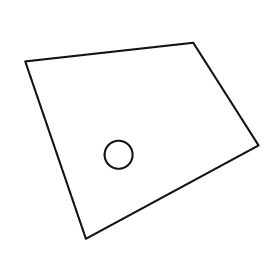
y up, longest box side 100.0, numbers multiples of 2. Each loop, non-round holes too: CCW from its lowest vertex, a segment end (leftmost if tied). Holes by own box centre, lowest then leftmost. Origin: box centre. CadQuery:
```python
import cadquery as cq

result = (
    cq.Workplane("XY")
    .moveTo(-24.0, -42.0)
    .lineTo(50.0, -2.0)
    .lineTo(22.0, 42.0)
    .lineTo(-50.0, 34.0)
    .close()
    .moveTo(-10.0, -6.0)
    .circle(6.0)
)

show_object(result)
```